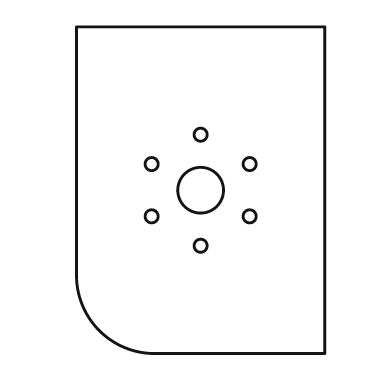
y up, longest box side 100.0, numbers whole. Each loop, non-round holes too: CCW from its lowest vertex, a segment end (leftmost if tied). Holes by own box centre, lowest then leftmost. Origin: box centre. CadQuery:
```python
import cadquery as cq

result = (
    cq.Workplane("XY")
    .moveTo(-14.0, -50.0)
    .lineTo(38.0, -50.0)
    .lineTo(38.0, 50.0)
    .lineTo(-38.0, 50.0)
    .lineTo(-38.0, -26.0)
    .threePointArc((-31.0, -43.0), (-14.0, -50.0))
    .close()
    .moveTo(0.0, -17.0)
    .circle(2.0)
    .moveTo(-15.0, -8.0)
    .circle(2.0)
    .moveTo(15.0, -8.0)
    .circle(2.0)
    .moveTo(0.0, 0.0)
    .circle(7.0)
    .moveTo(-15.0, 8.0)
    .circle(2.0)
    .moveTo(15.0, 8.0)
    .circle(2.0)
    .moveTo(0.0, 17.0)
    .circle(2.0)
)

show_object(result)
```